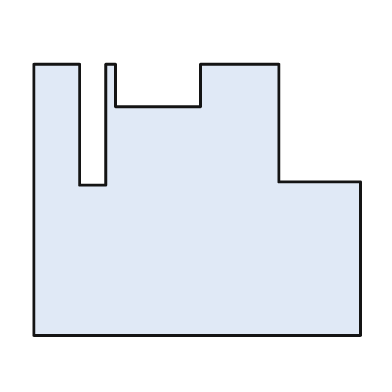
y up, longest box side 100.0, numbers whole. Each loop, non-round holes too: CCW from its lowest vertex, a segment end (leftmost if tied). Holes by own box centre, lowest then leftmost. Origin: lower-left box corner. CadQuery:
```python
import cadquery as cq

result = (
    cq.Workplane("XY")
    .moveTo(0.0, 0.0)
    .lineTo(100.0, 0.0)
    .lineTo(100.0, 47.0)
    .lineTo(75.0, 47.0)
    .lineTo(75.0, 83.0)
    .lineTo(51.0, 83.0)
    .lineTo(51.0, 70.0)
    .lineTo(25.0, 70.0)
    .lineTo(25.0, 83.0)
    .lineTo(22.0, 83.0)
    .lineTo(22.0, 46.0)
    .lineTo(14.0, 46.0)
    .lineTo(14.0, 83.0)
    .lineTo(0.0, 83.0)
    .close()
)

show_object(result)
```